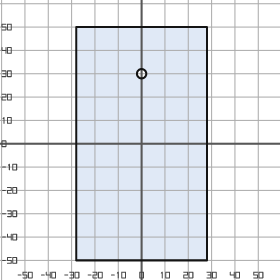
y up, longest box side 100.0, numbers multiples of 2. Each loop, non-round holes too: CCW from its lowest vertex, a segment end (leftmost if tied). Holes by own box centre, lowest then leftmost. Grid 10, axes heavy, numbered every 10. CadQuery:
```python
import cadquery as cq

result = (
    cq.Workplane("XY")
    .moveTo(-28.0, -50.0)
    .lineTo(28.0, -50.0)
    .lineTo(28.0, 50.0)
    .lineTo(-28.0, 50.0)
    .close()
    .moveTo(0.0, 30.0)
    .circle(2.0)
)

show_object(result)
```